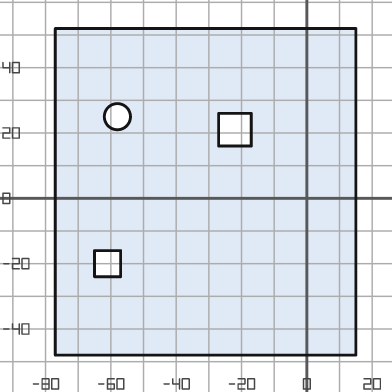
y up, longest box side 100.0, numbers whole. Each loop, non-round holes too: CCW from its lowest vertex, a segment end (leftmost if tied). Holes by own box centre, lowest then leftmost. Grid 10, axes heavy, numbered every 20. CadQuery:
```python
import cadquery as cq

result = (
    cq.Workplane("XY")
    .moveTo(-77.0, -48.0)
    .lineTo(15.0, -48.0)
    .lineTo(15.0, 52.0)
    .lineTo(-77.0, 52.0)
    .close()
    .moveTo(-65.0, -24.0)
    .lineTo(-57.0, -24.0)
    .lineTo(-57.0, -16.0)
    .lineTo(-65.0, -16.0)
    .close()
    .moveTo(-27.0, 16.0)
    .lineTo(-17.0, 16.0)
    .lineTo(-17.0, 26.0)
    .lineTo(-27.0, 26.0)
    .close()
    .moveTo(-58.0, 25.0)
    .circle(4.0)
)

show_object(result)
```